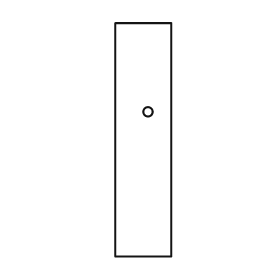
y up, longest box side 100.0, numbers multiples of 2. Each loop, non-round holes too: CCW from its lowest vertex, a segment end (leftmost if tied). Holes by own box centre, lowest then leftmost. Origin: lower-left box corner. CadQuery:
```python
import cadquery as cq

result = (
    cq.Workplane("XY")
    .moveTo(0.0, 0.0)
    .lineTo(24.0, 0.0)
    .lineTo(24.0, 100.0)
    .lineTo(0.0, 100.0)
    .close()
    .moveTo(14.0, 62.0)
    .circle(2.0)
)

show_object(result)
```